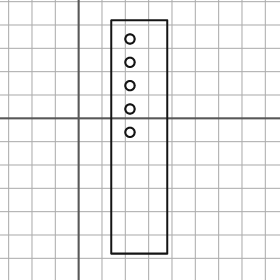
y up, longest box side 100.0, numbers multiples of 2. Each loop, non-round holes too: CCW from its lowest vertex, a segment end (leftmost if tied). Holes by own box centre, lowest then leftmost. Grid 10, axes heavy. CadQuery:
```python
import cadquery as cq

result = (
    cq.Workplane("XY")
    .moveTo(14.0, -58.0)
    .lineTo(38.0, -58.0)
    .lineTo(38.0, 42.0)
    .lineTo(14.0, 42.0)
    .close()
    .moveTo(22.0, -6.0)
    .circle(2.0)
    .moveTo(22.0, 4.0)
    .circle(2.0)
    .moveTo(22.0, 14.0)
    .circle(2.0)
    .moveTo(22.0, 24.0)
    .circle(2.0)
    .moveTo(22.0, 34.0)
    .circle(2.0)
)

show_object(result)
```